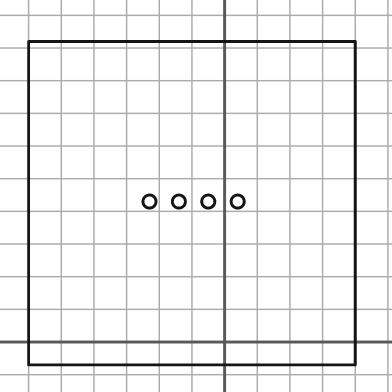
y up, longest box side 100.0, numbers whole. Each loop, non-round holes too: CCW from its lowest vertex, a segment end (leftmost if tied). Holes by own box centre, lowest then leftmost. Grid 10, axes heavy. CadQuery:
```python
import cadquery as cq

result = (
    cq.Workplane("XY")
    .moveTo(-60.0, -7.0)
    .lineTo(40.0, -7.0)
    .lineTo(40.0, 92.0)
    .lineTo(-60.0, 92.0)
    .close()
    .moveTo(-23.0, 43.0)
    .circle(2.0)
    .moveTo(-14.0, 43.0)
    .circle(2.0)
    .moveTo(-5.0, 43.0)
    .circle(2.0)
    .moveTo(4.0, 43.0)
    .circle(2.0)
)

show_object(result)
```